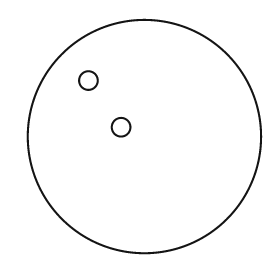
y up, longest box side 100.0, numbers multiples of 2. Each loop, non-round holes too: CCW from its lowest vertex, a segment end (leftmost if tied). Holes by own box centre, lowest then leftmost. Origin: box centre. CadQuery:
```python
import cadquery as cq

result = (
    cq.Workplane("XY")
    .moveTo(0.0, 0.0)
    .circle(50.0)
    .moveTo(-10.0, 4.0)
    .circle(4.0)
    .moveTo(-24.0, 24.0)
    .circle(4.0)
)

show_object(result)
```